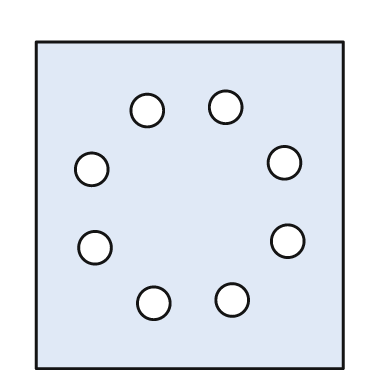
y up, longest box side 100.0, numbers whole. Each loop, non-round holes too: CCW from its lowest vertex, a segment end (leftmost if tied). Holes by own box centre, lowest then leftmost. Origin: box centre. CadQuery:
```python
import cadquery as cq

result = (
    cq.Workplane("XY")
    .moveTo(-47.0, -50.0)
    .lineTo(47.0, -50.0)
    .lineTo(47.0, 50.0)
    .lineTo(-47.0, 50.0)
    .close()
    .moveTo(-11.0, -30.0)
    .circle(5.0)
    .moveTo(13.0, -29.0)
    .circle(5.0)
    .moveTo(-29.0, -13.0)
    .circle(5.0)
    .moveTo(30.0, -11.0)
    .circle(5.0)
    .moveTo(-30.0, 11.0)
    .circle(5.0)
    .moveTo(29.0, 13.0)
    .circle(5.0)
    .moveTo(-13.0, 29.0)
    .circle(5.0)
    .moveTo(11.0, 30.0)
    .circle(5.0)
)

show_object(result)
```